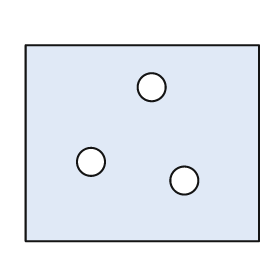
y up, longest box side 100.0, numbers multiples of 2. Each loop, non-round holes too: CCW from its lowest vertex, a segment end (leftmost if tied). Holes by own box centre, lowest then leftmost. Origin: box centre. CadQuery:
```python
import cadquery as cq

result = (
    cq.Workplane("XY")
    .moveTo(-50.0, -42.0)
    .lineTo(50.0, -42.0)
    .lineTo(50.0, 42.0)
    .lineTo(-50.0, 42.0)
    .close()
    .moveTo(18.0, -16.0)
    .circle(6.0)
    .moveTo(-22.0, -8.0)
    .circle(6.0)
    .moveTo(4.0, 24.0)
    .circle(6.0)
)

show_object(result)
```